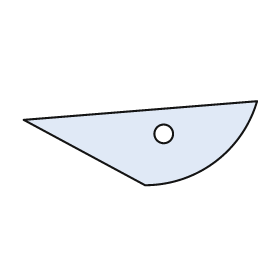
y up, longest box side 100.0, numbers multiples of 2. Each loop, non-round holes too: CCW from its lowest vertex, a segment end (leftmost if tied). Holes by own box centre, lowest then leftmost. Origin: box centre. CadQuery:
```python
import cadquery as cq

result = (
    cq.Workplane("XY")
    .moveTo(2.0, -18.0)
    .threePointArc((32.0, -8.0), (50.0, 18.0))
    .lineTo(-50.0, 10.0)
    .close()
    .moveTo(10.0, 4.0)
    .circle(4.0)
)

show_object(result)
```